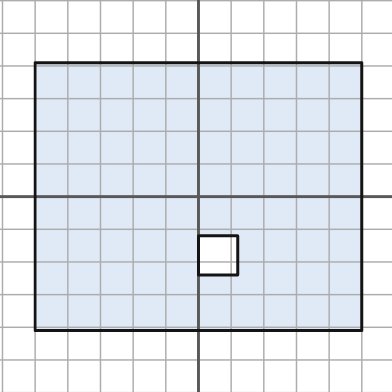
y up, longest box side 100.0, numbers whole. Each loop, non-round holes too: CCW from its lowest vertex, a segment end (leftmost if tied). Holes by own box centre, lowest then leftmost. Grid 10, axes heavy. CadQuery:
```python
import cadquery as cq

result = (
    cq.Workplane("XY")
    .moveTo(-50.0, -41.0)
    .lineTo(50.0, -41.0)
    .lineTo(50.0, 41.0)
    .lineTo(-50.0, 41.0)
    .close()
    .moveTo(0.0, -24.0)
    .lineTo(12.0, -24.0)
    .lineTo(12.0, -12.0)
    .lineTo(0.0, -12.0)
    .close()
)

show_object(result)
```